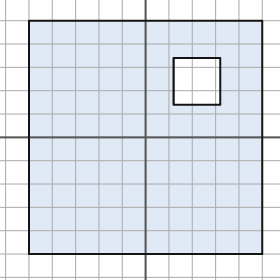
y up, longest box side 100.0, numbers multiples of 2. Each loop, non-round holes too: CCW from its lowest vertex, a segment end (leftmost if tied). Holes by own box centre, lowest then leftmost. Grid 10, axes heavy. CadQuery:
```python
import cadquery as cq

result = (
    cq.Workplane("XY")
    .moveTo(-50.0, -50.0)
    .lineTo(50.0, -50.0)
    .lineTo(50.0, 50.0)
    .lineTo(-50.0, 50.0)
    .close()
    .moveTo(12.0, 14.0)
    .lineTo(32.0, 14.0)
    .lineTo(32.0, 34.0)
    .lineTo(12.0, 34.0)
    .close()
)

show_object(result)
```